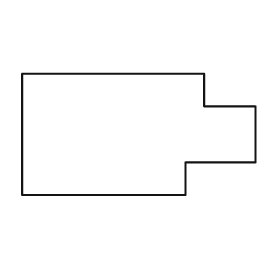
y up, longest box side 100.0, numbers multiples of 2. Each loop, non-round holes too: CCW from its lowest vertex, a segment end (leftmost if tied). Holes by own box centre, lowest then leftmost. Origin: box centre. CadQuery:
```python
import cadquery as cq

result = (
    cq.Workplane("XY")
    .moveTo(-50.0, -26.0)
    .lineTo(20.0, -26.0)
    .lineTo(20.0, -12.0)
    .lineTo(50.0, -12.0)
    .lineTo(50.0, 12.0)
    .lineTo(28.0, 12.0)
    .lineTo(28.0, 26.0)
    .lineTo(-50.0, 26.0)
    .close()
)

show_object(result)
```